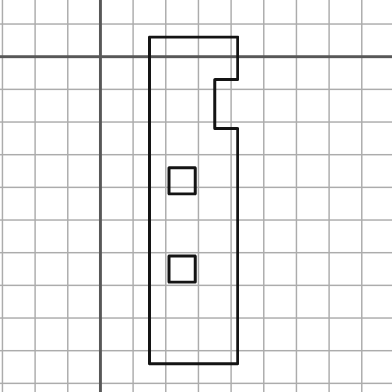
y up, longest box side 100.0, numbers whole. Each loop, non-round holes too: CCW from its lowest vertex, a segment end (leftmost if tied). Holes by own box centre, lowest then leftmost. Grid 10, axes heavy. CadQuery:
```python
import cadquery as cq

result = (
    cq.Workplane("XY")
    .moveTo(15.0, -94.0)
    .lineTo(42.0, -94.0)
    .lineTo(42.0, -22.0)
    .lineTo(35.0, -22.0)
    .lineTo(35.0, -7.0)
    .lineTo(42.0, -7.0)
    .lineTo(42.0, 6.0)
    .lineTo(15.0, 6.0)
    .close()
    .moveTo(21.0, -69.0)
    .lineTo(29.0, -69.0)
    .lineTo(29.0, -61.0)
    .lineTo(21.0, -61.0)
    .close()
    .moveTo(21.0, -42.0)
    .lineTo(29.0, -42.0)
    .lineTo(29.0, -34.0)
    .lineTo(21.0, -34.0)
    .close()
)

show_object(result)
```